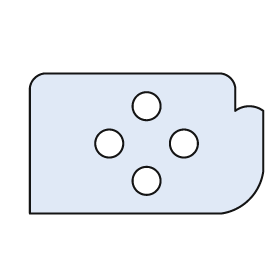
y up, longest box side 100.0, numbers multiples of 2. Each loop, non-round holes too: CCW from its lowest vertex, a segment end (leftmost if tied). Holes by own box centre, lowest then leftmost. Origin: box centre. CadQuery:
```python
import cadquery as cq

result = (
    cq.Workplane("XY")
    .moveTo(-50.0, -30.0)
    .lineTo(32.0, -30.0)
    .threePointArc((44.0, -24.0), (50.0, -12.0))
    .lineTo(50.0, 14.0)
    .threePointArc((44.0, 16.0), (38.0, 14.0))
    .lineTo(38.0, 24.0)
    .threePointArc((36.0, 28.0), (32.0, 30.0))
    .lineTo(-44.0, 30.0)
    .threePointArc((-48.0, 28.0), (-50.0, 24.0))
    .close()
    .moveTo(0.0, -16.0)
    .circle(6.0)
    .moveTo(-16.0, 0.0)
    .circle(6.0)
    .moveTo(16.0, 0.0)
    .circle(6.0)
    .moveTo(0.0, 16.0)
    .circle(6.0)
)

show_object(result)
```